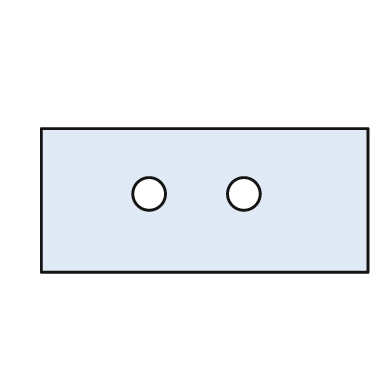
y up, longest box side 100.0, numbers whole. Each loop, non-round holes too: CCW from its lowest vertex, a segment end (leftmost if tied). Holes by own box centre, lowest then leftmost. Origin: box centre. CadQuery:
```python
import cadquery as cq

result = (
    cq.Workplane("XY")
    .moveTo(-50.0, -22.0)
    .lineTo(50.0, -22.0)
    .lineTo(50.0, 22.0)
    .lineTo(-50.0, 22.0)
    .close()
    .moveTo(-17.0, 2.0)
    .circle(5.0)
    .moveTo(12.0, 2.0)
    .circle(5.0)
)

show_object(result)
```